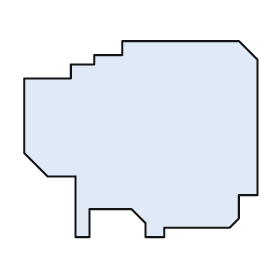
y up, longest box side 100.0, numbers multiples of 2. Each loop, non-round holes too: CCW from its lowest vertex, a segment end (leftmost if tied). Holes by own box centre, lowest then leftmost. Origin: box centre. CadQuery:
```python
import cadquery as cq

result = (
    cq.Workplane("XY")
    .moveTo(-28.0, -42.0)
    .lineTo(-22.0, -42.0)
    .lineTo(-22.0, -30.0)
    .lineTo(-4.0, -30.0)
    .lineTo(2.0, -36.0)
    .lineTo(2.0, -42.0)
    .lineTo(10.0, -42.0)
    .lineTo(10.0, -38.0)
    .lineTo(38.0, -38.0)
    .lineTo(42.0, -34.0)
    .lineTo(42.0, -24.0)
    .lineTo(50.0, -24.0)
    .lineTo(50.0, 34.0)
    .lineTo(42.0, 42.0)
    .lineTo(-8.0, 42.0)
    .lineTo(-8.0, 36.0)
    .lineTo(-20.0, 36.0)
    .lineTo(-20.0, 32.0)
    .lineTo(-30.0, 32.0)
    .lineTo(-30.0, 26.0)
    .lineTo(-50.0, 26.0)
    .lineTo(-50.0, -6.0)
    .lineTo(-40.0, -16.0)
    .lineTo(-28.0, -16.0)
    .close()
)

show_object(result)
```